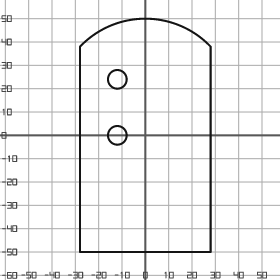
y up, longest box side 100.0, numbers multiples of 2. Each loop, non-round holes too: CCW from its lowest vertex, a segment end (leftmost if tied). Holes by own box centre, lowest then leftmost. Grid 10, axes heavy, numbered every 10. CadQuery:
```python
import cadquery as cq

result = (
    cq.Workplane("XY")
    .moveTo(-28.0, -50.0)
    .lineTo(28.0, -50.0)
    .lineTo(28.0, 38.0)
    .threePointArc((0.0, 50.0), (-28.0, 38.0))
    .close()
    .moveTo(-12.0, 0.0)
    .circle(4.0)
    .moveTo(-12.0, 24.0)
    .circle(4.0)
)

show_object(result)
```